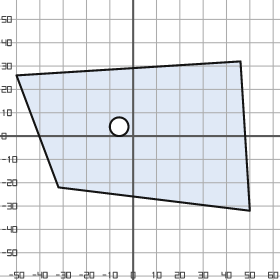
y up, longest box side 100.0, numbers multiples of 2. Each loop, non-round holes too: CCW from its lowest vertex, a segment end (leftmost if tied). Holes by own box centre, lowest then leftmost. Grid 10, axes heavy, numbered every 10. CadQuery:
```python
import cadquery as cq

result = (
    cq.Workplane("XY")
    .moveTo(50.0, -32.0)
    .lineTo(46.0, 32.0)
    .lineTo(-50.0, 26.0)
    .lineTo(-32.0, -22.0)
    .close()
    .moveTo(-6.0, 4.0)
    .circle(4.0)
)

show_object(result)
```